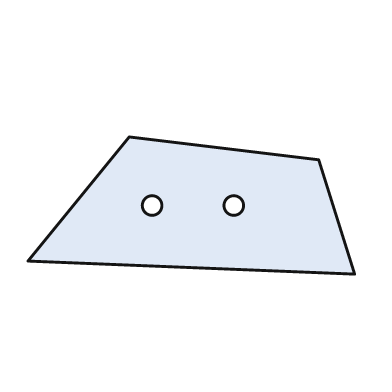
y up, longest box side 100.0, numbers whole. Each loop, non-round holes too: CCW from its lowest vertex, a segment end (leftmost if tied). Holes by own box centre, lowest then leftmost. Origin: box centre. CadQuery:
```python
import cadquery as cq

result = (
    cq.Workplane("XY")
    .moveTo(50.0, -21.0)
    .lineTo(39.0, 14.0)
    .lineTo(-19.0, 21.0)
    .lineTo(-50.0, -17.0)
    .close()
    .moveTo(-12.0, 0.0)
    .circle(3.0)
    .moveTo(13.0, 0.0)
    .circle(3.0)
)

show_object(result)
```